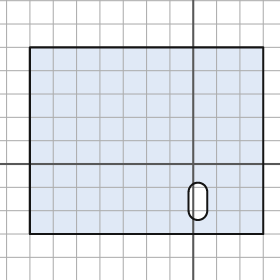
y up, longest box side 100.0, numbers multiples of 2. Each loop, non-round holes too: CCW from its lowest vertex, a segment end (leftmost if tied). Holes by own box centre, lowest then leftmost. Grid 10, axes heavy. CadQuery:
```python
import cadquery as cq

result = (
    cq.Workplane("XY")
    .moveTo(-70.0, -30.0)
    .lineTo(30.0, -30.0)
    .lineTo(30.0, 50.0)
    .lineTo(-70.0, 50.0)
    .close()
    .moveTo(-2.0, -20.0)
    .threePointArc((2.0, -24.0), (6.0, -20.0))
    .lineTo(6.0, -12.0)
    .threePointArc((2.0, -8.0), (-2.0, -12.0))
    .close()
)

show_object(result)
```